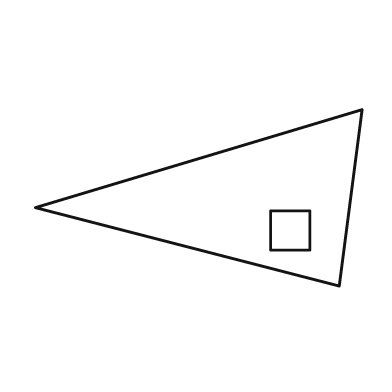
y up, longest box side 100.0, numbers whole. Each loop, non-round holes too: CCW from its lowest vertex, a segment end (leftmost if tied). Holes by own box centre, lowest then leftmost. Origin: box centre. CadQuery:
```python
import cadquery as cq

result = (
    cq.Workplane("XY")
    .moveTo(43.0, -27.0)
    .lineTo(50.0, 27.0)
    .lineTo(-50.0, -3.0)
    .close()
    .moveTo(22.0, -16.0)
    .lineTo(34.0, -16.0)
    .lineTo(34.0, -4.0)
    .lineTo(22.0, -4.0)
    .close()
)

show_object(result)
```